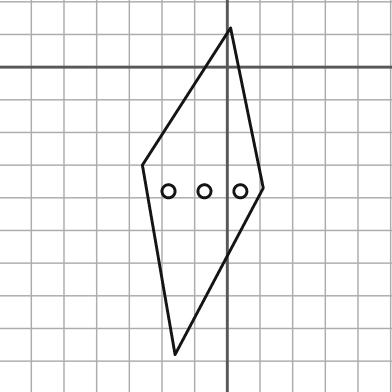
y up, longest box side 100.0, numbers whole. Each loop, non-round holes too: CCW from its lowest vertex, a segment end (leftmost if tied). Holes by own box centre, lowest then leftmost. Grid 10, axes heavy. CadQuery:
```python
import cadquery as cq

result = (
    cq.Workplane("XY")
    .moveTo(-16.0, -88.0)
    .lineTo(11.0, -37.0)
    .lineTo(1.0, 12.0)
    .lineTo(-26.0, -30.0)
    .close()
    .moveTo(-18.0, -38.0)
    .circle(2.0)
    .moveTo(-7.0, -38.0)
    .circle(2.0)
    .moveTo(4.0, -38.0)
    .circle(2.0)
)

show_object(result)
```